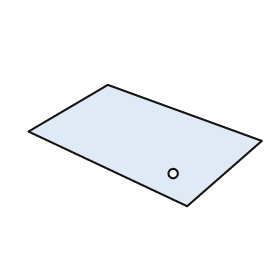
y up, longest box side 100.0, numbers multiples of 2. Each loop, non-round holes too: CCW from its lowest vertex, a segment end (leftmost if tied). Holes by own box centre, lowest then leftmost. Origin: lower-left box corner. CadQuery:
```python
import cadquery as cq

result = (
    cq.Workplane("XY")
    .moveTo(68.0, 0.0)
    .lineTo(100.0, 28.0)
    .lineTo(34.0, 52.0)
    .lineTo(0.0, 32.0)
    .close()
    .moveTo(62.0, 14.0)
    .circle(2.0)
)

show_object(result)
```